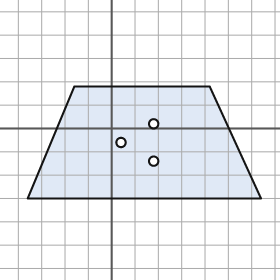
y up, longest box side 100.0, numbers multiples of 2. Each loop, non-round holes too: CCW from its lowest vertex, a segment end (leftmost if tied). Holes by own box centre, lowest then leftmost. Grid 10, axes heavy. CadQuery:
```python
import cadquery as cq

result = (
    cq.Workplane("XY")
    .moveTo(-36.0, -30.0)
    .lineTo(64.0, -30.0)
    .lineTo(42.0, 18.0)
    .lineTo(-16.0, 18.0)
    .close()
    .moveTo(18.0, -14.0)
    .circle(2.0)
    .moveTo(4.0, -6.0)
    .circle(2.0)
    .moveTo(18.0, 2.0)
    .circle(2.0)
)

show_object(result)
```